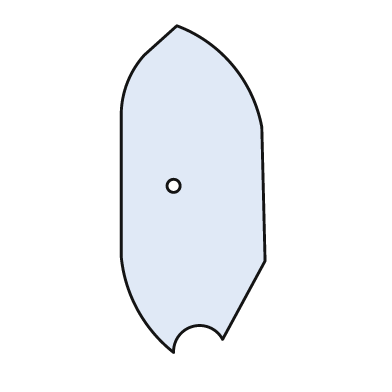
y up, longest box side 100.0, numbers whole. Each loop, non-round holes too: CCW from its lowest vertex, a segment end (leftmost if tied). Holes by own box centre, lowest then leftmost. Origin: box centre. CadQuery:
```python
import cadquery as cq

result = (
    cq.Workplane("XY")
    .moveTo(-6.0, -50.0)
    .threePointArc((0.0, -42.0), (9.0, -46.0))
    .lineTo(22.0, -22.0)
    .lineTo(21.0, 19.0)
    .threePointArc((12.0, 38.0), (-5.0, 50.0))
    .lineTo(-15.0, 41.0)
    .threePointArc((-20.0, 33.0), (-22.0, 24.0))
    .lineTo(-22.0, -21.0)
    .threePointArc((-17.0, -37.0), (-6.0, -50.0))
    .close()
    .moveTo(-6.0, 1.0)
    .circle(2.0)
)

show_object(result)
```